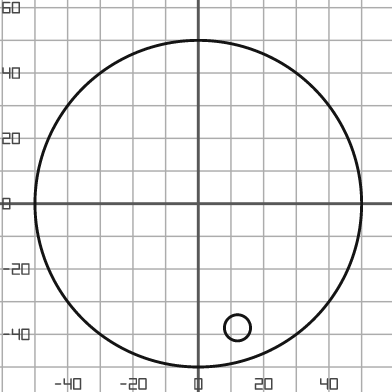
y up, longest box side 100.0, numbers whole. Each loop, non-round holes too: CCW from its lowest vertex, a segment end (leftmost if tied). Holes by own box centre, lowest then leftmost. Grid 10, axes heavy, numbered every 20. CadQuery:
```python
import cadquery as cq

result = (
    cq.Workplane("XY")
    .moveTo(0.0, 0.0)
    .circle(50.0)
    .moveTo(12.0, -38.0)
    .circle(4.0)
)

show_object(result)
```